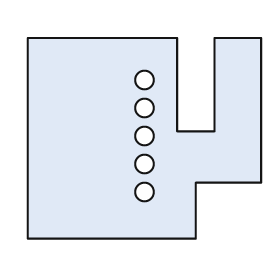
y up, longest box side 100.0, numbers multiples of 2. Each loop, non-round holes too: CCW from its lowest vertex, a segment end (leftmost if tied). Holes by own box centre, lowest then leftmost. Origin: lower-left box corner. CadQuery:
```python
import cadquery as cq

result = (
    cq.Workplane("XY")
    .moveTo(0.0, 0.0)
    .lineTo(72.0, 0.0)
    .lineTo(72.0, 24.0)
    .lineTo(100.0, 24.0)
    .lineTo(100.0, 86.0)
    .lineTo(80.0, 86.0)
    .lineTo(80.0, 46.0)
    .lineTo(64.0, 46.0)
    .lineTo(64.0, 86.0)
    .lineTo(0.0, 86.0)
    .close()
    .moveTo(50.0, 20.0)
    .circle(4.0)
    .moveTo(50.0, 32.0)
    .circle(4.0)
    .moveTo(50.0, 44.0)
    .circle(4.0)
    .moveTo(50.0, 56.0)
    .circle(4.0)
    .moveTo(50.0, 68.0)
    .circle(4.0)
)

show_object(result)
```